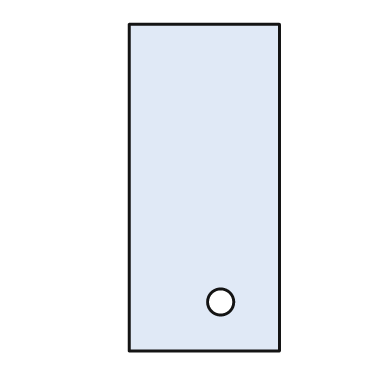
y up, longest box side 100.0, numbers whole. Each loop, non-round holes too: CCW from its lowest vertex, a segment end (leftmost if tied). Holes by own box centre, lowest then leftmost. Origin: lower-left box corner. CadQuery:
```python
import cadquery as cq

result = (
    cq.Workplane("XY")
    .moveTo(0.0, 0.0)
    .lineTo(46.0, 0.0)
    .lineTo(46.0, 100.0)
    .lineTo(0.0, 100.0)
    .close()
    .moveTo(28.0, 15.0)
    .circle(4.0)
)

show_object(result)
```